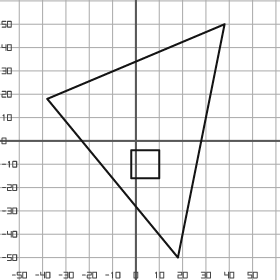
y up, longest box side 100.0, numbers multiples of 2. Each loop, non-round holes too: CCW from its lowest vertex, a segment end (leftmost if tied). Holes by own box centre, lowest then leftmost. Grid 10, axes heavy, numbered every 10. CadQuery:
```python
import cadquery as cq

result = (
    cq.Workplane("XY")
    .moveTo(18.0, -50.0)
    .lineTo(38.0, 50.0)
    .lineTo(-38.0, 18.0)
    .close()
    .moveTo(-2.0, -16.0)
    .lineTo(10.0, -16.0)
    .lineTo(10.0, -4.0)
    .lineTo(-2.0, -4.0)
    .close()
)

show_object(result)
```